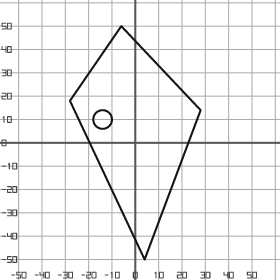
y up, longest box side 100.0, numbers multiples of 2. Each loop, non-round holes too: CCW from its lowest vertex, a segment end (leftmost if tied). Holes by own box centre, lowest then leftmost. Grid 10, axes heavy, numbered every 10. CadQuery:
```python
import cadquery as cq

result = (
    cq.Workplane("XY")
    .moveTo(4.0, -50.0)
    .lineTo(28.0, 14.0)
    .lineTo(-6.0, 50.0)
    .lineTo(-28.0, 18.0)
    .close()
    .moveTo(-14.0, 10.0)
    .circle(4.0)
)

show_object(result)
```